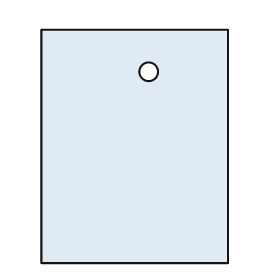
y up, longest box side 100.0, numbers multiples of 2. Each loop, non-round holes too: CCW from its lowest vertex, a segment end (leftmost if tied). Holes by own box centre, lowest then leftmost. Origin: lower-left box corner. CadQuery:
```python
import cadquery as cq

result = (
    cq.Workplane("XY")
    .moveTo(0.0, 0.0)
    .lineTo(80.0, 0.0)
    .lineTo(80.0, 100.0)
    .lineTo(0.0, 100.0)
    .close()
    .moveTo(46.0, 82.0)
    .circle(4.0)
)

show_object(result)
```